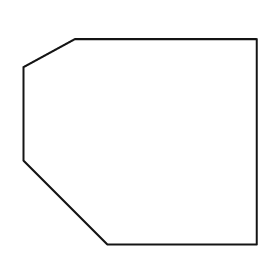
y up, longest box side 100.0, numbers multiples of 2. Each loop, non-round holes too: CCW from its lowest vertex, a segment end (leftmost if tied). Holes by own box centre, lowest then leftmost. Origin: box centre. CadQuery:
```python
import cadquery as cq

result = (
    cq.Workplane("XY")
    .moveTo(-14.0, -44.0)
    .lineTo(50.0, -44.0)
    .lineTo(50.0, 44.0)
    .lineTo(-28.0, 44.0)
    .lineTo(-50.0, 32.0)
    .lineTo(-50.0, -8.0)
    .close()
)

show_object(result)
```